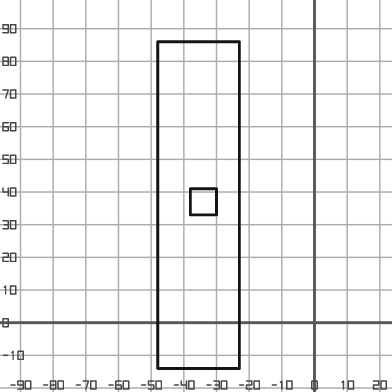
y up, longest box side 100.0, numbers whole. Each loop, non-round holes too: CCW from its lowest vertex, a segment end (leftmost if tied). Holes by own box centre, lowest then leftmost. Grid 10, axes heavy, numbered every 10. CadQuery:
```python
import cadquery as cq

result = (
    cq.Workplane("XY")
    .moveTo(-48.0, -14.0)
    .lineTo(-23.0, -14.0)
    .lineTo(-23.0, 86.0)
    .lineTo(-48.0, 86.0)
    .close()
    .moveTo(-38.0, 33.0)
    .lineTo(-30.0, 33.0)
    .lineTo(-30.0, 41.0)
    .lineTo(-38.0, 41.0)
    .close()
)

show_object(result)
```